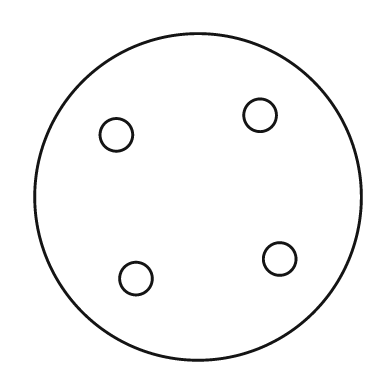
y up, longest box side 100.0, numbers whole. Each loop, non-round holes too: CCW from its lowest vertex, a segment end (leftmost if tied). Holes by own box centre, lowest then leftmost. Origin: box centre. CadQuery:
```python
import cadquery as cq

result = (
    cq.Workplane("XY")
    .moveTo(0.0, 0.0)
    .circle(50.0)
    .moveTo(-19.0, -25.0)
    .circle(5.0)
    .moveTo(25.0, -19.0)
    .circle(5.0)
    .moveTo(-25.0, 19.0)
    .circle(5.0)
    .moveTo(19.0, 25.0)
    .circle(5.0)
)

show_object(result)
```